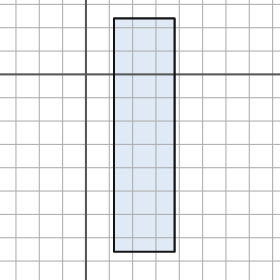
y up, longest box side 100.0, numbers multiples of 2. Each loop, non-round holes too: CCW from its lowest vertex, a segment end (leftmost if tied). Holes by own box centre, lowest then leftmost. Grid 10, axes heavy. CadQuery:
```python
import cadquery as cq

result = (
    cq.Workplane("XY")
    .moveTo(12.0, -76.0)
    .lineTo(38.0, -76.0)
    .lineTo(38.0, 24.0)
    .lineTo(12.0, 24.0)
    .close()
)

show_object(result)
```